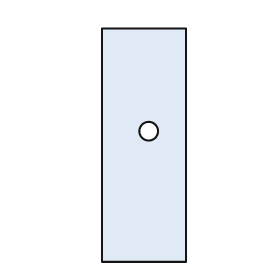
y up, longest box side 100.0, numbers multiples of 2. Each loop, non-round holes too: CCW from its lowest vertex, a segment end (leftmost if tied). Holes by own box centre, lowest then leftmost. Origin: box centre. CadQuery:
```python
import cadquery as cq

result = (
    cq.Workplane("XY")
    .moveTo(-18.0, -50.0)
    .lineTo(18.0, -50.0)
    .lineTo(18.0, 50.0)
    .lineTo(-18.0, 50.0)
    .close()
    .moveTo(2.0, 6.0)
    .circle(4.0)
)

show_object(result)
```